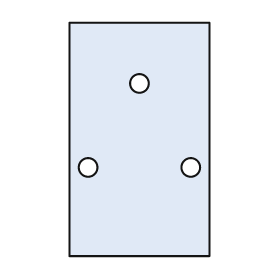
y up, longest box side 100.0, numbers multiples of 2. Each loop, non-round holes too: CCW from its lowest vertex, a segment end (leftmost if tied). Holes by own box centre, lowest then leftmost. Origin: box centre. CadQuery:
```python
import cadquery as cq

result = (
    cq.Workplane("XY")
    .moveTo(-30.0, -50.0)
    .lineTo(30.0, -50.0)
    .lineTo(30.0, 50.0)
    .lineTo(-30.0, 50.0)
    .close()
    .moveTo(-22.0, -12.0)
    .circle(4.0)
    .moveTo(22.0, -12.0)
    .circle(4.0)
    .moveTo(0.0, 24.0)
    .circle(4.0)
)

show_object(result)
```